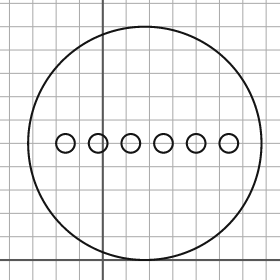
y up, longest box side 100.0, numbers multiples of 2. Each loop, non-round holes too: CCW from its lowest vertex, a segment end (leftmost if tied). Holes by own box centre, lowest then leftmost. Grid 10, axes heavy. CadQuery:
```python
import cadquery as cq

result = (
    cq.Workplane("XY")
    .moveTo(18.0, 50.0)
    .circle(50.0)
    .moveTo(-16.0, 50.0)
    .circle(4.0)
    .moveTo(-2.0, 50.0)
    .circle(4.0)
    .moveTo(12.0, 50.0)
    .circle(4.0)
    .moveTo(26.0, 50.0)
    .circle(4.0)
    .moveTo(40.0, 50.0)
    .circle(4.0)
    .moveTo(54.0, 50.0)
    .circle(4.0)
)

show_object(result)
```